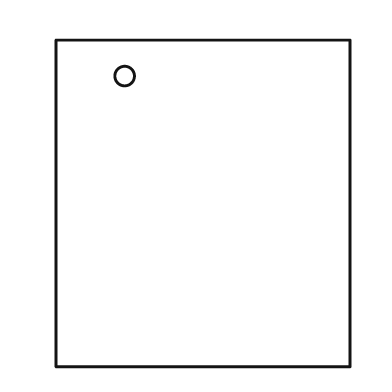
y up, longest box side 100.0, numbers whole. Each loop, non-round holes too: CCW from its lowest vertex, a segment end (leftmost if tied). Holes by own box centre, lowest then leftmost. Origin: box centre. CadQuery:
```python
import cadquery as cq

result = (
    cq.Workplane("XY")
    .moveTo(-45.0, -50.0)
    .lineTo(45.0, -50.0)
    .lineTo(45.0, 50.0)
    .lineTo(-45.0, 50.0)
    .close()
    .moveTo(-24.0, 39.0)
    .circle(3.0)
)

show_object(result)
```